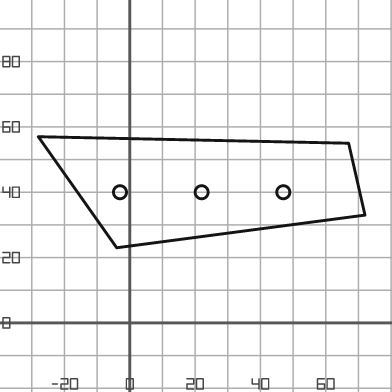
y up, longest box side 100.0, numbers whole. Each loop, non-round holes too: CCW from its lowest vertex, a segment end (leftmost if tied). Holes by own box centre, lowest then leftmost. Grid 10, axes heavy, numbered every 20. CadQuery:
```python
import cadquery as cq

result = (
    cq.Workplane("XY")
    .moveTo(-4.0, 23.0)
    .lineTo(72.0, 33.0)
    .lineTo(67.0, 55.0)
    .lineTo(-28.0, 57.0)
    .close()
    .moveTo(-3.0, 40.0)
    .circle(2.0)
    .moveTo(22.0, 40.0)
    .circle(2.0)
    .moveTo(47.0, 40.0)
    .circle(2.0)
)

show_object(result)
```